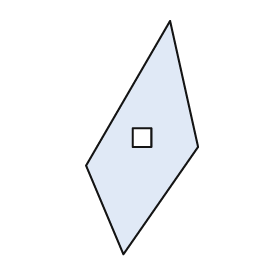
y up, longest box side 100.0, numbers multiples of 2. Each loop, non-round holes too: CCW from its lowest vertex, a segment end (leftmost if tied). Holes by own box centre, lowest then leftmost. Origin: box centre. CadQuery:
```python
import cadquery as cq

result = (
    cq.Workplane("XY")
    .moveTo(-8.0, -50.0)
    .lineTo(24.0, -4.0)
    .lineTo(12.0, 50.0)
    .lineTo(-24.0, -12.0)
    .close()
    .moveTo(-4.0, -4.0)
    .lineTo(4.0, -4.0)
    .lineTo(4.0, 4.0)
    .lineTo(-4.0, 4.0)
    .close()
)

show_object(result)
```